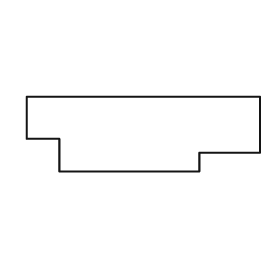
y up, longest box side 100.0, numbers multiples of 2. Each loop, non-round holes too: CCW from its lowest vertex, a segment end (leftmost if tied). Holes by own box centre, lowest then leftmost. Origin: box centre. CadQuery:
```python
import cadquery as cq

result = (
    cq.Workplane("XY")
    .moveTo(-36.0, -16.0)
    .lineTo(24.0, -16.0)
    .lineTo(24.0, -8.0)
    .lineTo(50.0, -8.0)
    .lineTo(50.0, 16.0)
    .lineTo(-50.0, 16.0)
    .lineTo(-50.0, -2.0)
    .lineTo(-36.0, -2.0)
    .close()
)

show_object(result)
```